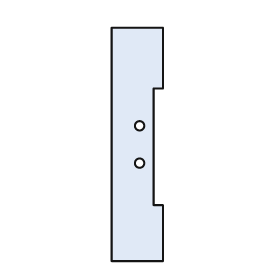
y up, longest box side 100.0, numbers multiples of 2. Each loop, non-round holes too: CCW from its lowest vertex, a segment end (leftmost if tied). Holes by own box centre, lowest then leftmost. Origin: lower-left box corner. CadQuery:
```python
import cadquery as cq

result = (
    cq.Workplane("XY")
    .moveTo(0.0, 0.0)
    .lineTo(22.0, 0.0)
    .lineTo(22.0, 24.0)
    .lineTo(18.0, 24.0)
    .lineTo(18.0, 74.0)
    .lineTo(22.0, 74.0)
    .lineTo(22.0, 100.0)
    .lineTo(0.0, 100.0)
    .close()
    .moveTo(12.0, 42.0)
    .circle(2.0)
    .moveTo(12.0, 58.0)
    .circle(2.0)
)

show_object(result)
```